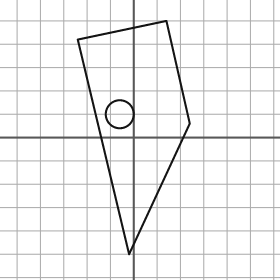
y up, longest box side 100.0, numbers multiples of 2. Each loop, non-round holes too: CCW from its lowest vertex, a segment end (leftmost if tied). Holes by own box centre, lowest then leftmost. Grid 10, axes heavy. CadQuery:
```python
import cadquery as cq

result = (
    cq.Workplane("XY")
    .moveTo(-2.0, -50.0)
    .lineTo(24.0, 6.0)
    .lineTo(14.0, 50.0)
    .lineTo(-24.0, 42.0)
    .close()
    .moveTo(-6.0, 10.0)
    .circle(6.0)
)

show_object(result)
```